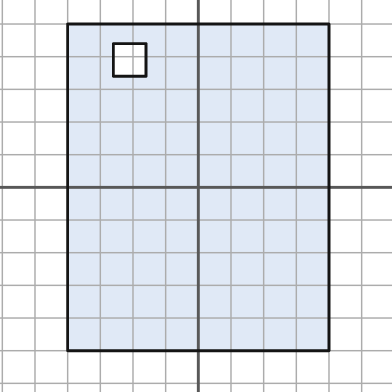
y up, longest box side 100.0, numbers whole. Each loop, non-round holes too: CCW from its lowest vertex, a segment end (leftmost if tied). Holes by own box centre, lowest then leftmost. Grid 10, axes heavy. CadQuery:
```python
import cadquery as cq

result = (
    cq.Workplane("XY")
    .moveTo(-40.0, -50.0)
    .lineTo(40.0, -50.0)
    .lineTo(40.0, 50.0)
    .lineTo(-40.0, 50.0)
    .close()
    .moveTo(-26.0, 34.0)
    .lineTo(-16.0, 34.0)
    .lineTo(-16.0, 44.0)
    .lineTo(-26.0, 44.0)
    .close()
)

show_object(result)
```